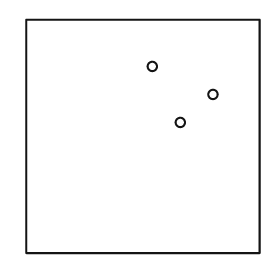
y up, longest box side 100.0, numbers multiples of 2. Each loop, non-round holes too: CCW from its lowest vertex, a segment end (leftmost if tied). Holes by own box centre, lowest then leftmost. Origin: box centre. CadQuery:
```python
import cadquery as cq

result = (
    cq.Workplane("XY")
    .moveTo(-50.0, -50.0)
    .lineTo(50.0, -50.0)
    .lineTo(50.0, 50.0)
    .lineTo(-50.0, 50.0)
    .close()
    .moveTo(16.0, 6.0)
    .circle(2.0)
    .moveTo(30.0, 18.0)
    .circle(2.0)
    .moveTo(4.0, 30.0)
    .circle(2.0)
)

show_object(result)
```